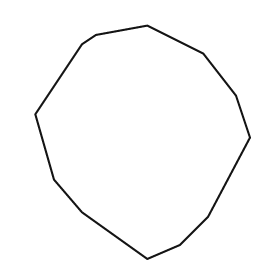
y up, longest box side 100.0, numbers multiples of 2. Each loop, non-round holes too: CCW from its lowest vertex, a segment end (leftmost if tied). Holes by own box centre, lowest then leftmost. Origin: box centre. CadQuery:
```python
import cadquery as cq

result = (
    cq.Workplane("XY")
    .moveTo(2.0, -50.0)
    .lineTo(16.0, -44.0)
    .lineTo(28.0, -32.0)
    .lineTo(46.0, 2.0)
    .lineTo(40.0, 20.0)
    .lineTo(26.0, 38.0)
    .lineTo(2.0, 50.0)
    .lineTo(-20.0, 46.0)
    .lineTo(-26.0, 42.0)
    .lineTo(-46.0, 12.0)
    .lineTo(-38.0, -16.0)
    .lineTo(-26.0, -30.0)
    .close()
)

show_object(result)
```